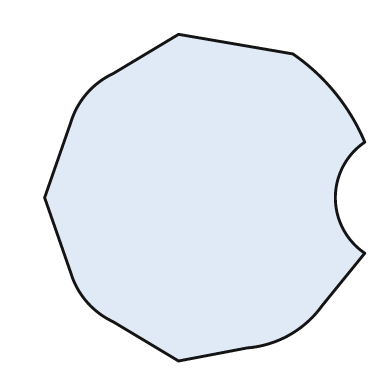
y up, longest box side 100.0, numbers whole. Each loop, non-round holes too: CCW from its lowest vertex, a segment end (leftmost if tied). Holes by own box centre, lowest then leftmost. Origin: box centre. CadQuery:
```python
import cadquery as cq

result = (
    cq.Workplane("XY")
    .moveTo(-8.0, -50.0)
    .lineTo(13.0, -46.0)
    .threePointArc((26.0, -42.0), (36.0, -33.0))
    .lineTo(49.0, -17.0)
    .threePointArc((40.0, 0.0), (49.0, 17.0))
    .threePointArc((40.0, 32.0), (27.0, 44.0))
    .lineTo(-8.0, 50.0)
    .lineTo(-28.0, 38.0)
    .threePointArc((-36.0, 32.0), (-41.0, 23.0))
    .lineTo(-49.0, 0.0)
    .lineTo(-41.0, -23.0)
    .threePointArc((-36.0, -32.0), (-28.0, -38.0))
    .close()
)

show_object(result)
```